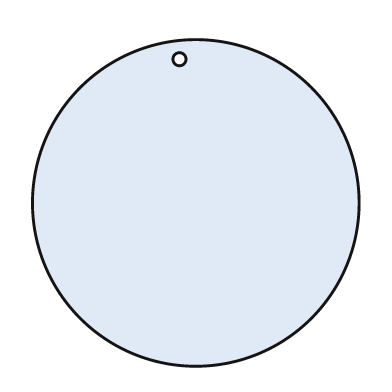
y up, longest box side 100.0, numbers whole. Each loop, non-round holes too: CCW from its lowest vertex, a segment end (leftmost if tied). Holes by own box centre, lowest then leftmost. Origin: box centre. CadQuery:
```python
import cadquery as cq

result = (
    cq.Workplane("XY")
    .moveTo(0.0, 0.0)
    .circle(50.0)
    .moveTo(-5.0, 44.0)
    .circle(2.0)
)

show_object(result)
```